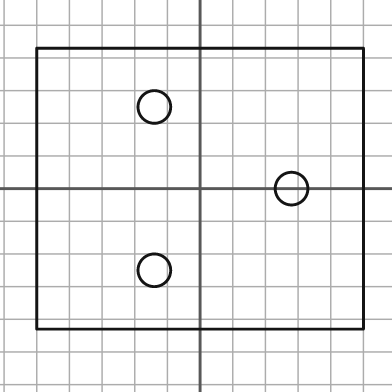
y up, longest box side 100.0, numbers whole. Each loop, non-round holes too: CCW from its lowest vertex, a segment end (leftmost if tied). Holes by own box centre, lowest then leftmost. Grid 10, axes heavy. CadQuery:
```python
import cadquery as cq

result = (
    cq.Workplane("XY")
    .moveTo(-50.0, -43.0)
    .lineTo(50.0, -43.0)
    .lineTo(50.0, 43.0)
    .lineTo(-50.0, 43.0)
    .close()
    .moveTo(-14.0, -25.0)
    .circle(5.0)
    .moveTo(28.0, 0.0)
    .circle(5.0)
    .moveTo(-14.0, 25.0)
    .circle(5.0)
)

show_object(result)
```